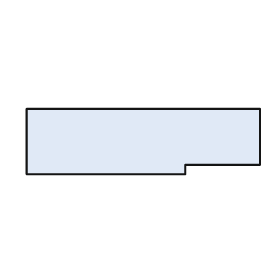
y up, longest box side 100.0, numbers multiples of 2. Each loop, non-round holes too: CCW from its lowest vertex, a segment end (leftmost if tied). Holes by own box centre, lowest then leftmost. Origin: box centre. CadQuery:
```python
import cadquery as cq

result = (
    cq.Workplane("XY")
    .moveTo(-50.0, -14.0)
    .lineTo(18.0, -14.0)
    .lineTo(18.0, -10.0)
    .lineTo(50.0, -10.0)
    .lineTo(50.0, 14.0)
    .lineTo(-50.0, 14.0)
    .close()
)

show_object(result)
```